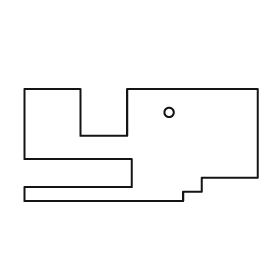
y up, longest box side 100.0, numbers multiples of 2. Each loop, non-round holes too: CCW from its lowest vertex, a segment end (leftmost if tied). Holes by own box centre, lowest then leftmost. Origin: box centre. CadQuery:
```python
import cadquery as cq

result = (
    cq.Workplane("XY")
    .moveTo(-50.0, -24.0)
    .lineTo(18.0, -24.0)
    .lineTo(18.0, -20.0)
    .lineTo(26.0, -20.0)
    .lineTo(26.0, -14.0)
    .lineTo(50.0, -14.0)
    .lineTo(50.0, 24.0)
    .lineTo(-6.0, 24.0)
    .lineTo(-6.0, 4.0)
    .lineTo(-26.0, 4.0)
    .lineTo(-26.0, 24.0)
    .lineTo(-50.0, 24.0)
    .lineTo(-50.0, -6.0)
    .lineTo(-4.0, -6.0)
    .lineTo(-4.0, -18.0)
    .lineTo(-50.0, -18.0)
    .close()
    .moveTo(12.0, 14.0)
    .circle(2.0)
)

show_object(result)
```